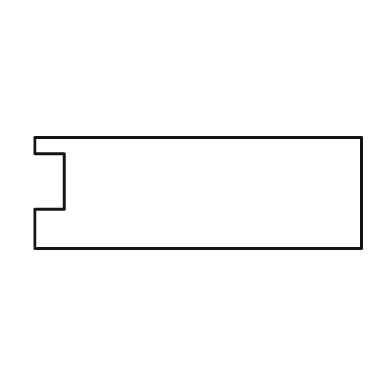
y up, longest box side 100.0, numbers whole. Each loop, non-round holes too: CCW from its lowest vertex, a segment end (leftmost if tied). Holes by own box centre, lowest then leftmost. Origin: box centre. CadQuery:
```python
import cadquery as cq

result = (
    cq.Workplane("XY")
    .moveTo(-50.0, -17.0)
    .lineTo(50.0, -17.0)
    .lineTo(50.0, 17.0)
    .lineTo(-50.0, 17.0)
    .lineTo(-50.0, 12.0)
    .lineTo(-41.0, 12.0)
    .lineTo(-41.0, -5.0)
    .lineTo(-50.0, -5.0)
    .close()
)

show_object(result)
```